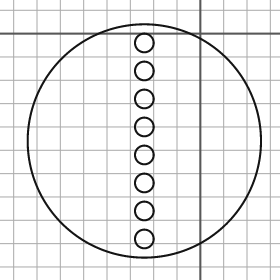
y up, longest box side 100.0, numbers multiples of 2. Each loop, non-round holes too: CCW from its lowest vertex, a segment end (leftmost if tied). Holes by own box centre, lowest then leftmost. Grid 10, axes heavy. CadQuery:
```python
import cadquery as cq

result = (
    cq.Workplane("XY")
    .moveTo(-24.0, -46.0)
    .circle(50.0)
    .moveTo(-24.0, -88.0)
    .circle(4.0)
    .moveTo(-24.0, -76.0)
    .circle(4.0)
    .moveTo(-24.0, -64.0)
    .circle(4.0)
    .moveTo(-24.0, -52.0)
    .circle(4.0)
    .moveTo(-24.0, -40.0)
    .circle(4.0)
    .moveTo(-24.0, -28.0)
    .circle(4.0)
    .moveTo(-24.0, -16.0)
    .circle(4.0)
    .moveTo(-24.0, -4.0)
    .circle(4.0)
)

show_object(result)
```